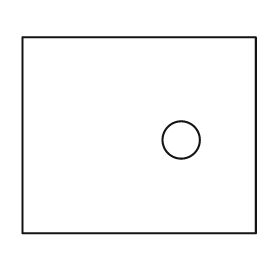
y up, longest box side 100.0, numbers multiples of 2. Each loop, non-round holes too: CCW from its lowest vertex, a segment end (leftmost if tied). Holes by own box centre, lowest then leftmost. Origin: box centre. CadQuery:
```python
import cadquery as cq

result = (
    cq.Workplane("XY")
    .moveTo(-50.0, -42.0)
    .lineTo(50.0, -42.0)
    .lineTo(50.0, 42.0)
    .lineTo(-50.0, 42.0)
    .close()
    .moveTo(18.0, -2.0)
    .circle(8.0)
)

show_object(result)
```